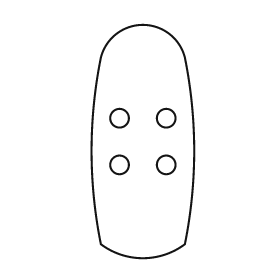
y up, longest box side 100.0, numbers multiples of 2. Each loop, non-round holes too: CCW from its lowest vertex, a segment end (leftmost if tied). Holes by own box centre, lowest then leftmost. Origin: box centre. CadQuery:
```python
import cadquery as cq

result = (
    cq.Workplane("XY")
    .moveTo(-18.0, -44.0)
    .threePointArc((0.0, -50.0), (18.0, -44.0))
    .threePointArc((22.0, -4.0), (18.0, 36.0))
    .threePointArc((0.0, 50.0), (-18.0, 36.0))
    .threePointArc((-22.0, -4.0), (-18.0, -44.0))
    .close()
    .moveTo(-10.0, -10.0)
    .circle(4.0)
    .moveTo(10.0, -10.0)
    .circle(4.0)
    .moveTo(-10.0, 10.0)
    .circle(4.0)
    .moveTo(10.0, 10.0)
    .circle(4.0)
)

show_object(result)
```